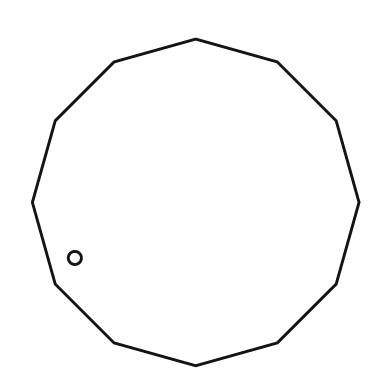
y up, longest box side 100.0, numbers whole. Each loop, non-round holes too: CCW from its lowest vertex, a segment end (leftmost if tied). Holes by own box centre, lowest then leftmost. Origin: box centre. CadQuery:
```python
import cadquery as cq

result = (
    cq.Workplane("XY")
    .moveTo(0.0, -50.0)
    .lineTo(25.0, -43.0)
    .lineTo(43.0, -25.0)
    .lineTo(50.0, 0.0)
    .lineTo(43.0, 25.0)
    .lineTo(25.0, 43.0)
    .lineTo(0.0, 50.0)
    .lineTo(-25.0, 43.0)
    .lineTo(-43.0, 25.0)
    .lineTo(-50.0, 0.0)
    .lineTo(-43.0, -25.0)
    .lineTo(-25.0, -43.0)
    .close()
    .moveTo(-37.0, -17.0)
    .circle(2.0)
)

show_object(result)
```